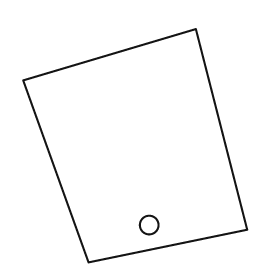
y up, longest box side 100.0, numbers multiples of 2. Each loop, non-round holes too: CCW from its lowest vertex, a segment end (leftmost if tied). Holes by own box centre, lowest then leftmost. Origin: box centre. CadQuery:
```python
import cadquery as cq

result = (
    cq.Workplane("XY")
    .moveTo(-20.0, -50.0)
    .lineTo(48.0, -36.0)
    .lineTo(26.0, 50.0)
    .lineTo(-48.0, 28.0)
    .close()
    .moveTo(6.0, -34.0)
    .circle(4.0)
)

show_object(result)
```